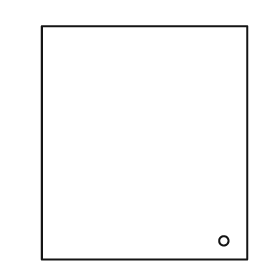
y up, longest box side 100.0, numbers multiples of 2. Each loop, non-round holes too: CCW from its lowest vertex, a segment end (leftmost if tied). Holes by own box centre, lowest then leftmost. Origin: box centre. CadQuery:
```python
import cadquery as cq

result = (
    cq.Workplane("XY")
    .moveTo(-44.0, -50.0)
    .lineTo(44.0, -50.0)
    .lineTo(44.0, 50.0)
    .lineTo(-44.0, 50.0)
    .close()
    .moveTo(34.0, -42.0)
    .circle(2.0)
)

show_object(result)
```